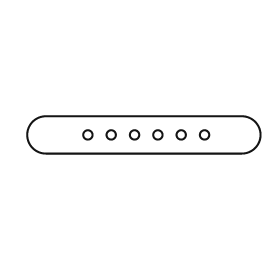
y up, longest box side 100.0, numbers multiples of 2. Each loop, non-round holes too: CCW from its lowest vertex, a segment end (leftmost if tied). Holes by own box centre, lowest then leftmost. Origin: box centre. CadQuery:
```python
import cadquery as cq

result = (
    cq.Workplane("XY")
    .moveTo(-42.0, -8.0)
    .lineTo(42.0, -8.0)
    .threePointArc((50.0, 0.0), (42.0, 8.0))
    .lineTo(-42.0, 8.0)
    .threePointArc((-50.0, 0.0), (-42.0, -8.0))
    .close()
    .moveTo(-24.0, 0.0)
    .circle(2.0)
    .moveTo(-14.0, 0.0)
    .circle(2.0)
    .moveTo(-4.0, 0.0)
    .circle(2.0)
    .moveTo(6.0, 0.0)
    .circle(2.0)
    .moveTo(16.0, 0.0)
    .circle(2.0)
    .moveTo(26.0, 0.0)
    .circle(2.0)
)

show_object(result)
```